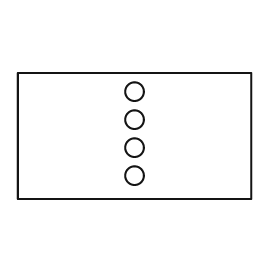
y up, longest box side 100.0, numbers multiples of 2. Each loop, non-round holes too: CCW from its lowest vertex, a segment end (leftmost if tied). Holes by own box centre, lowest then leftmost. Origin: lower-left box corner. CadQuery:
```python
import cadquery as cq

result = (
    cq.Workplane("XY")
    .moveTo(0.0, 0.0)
    .lineTo(100.0, 0.0)
    .lineTo(100.0, 54.0)
    .lineTo(0.0, 54.0)
    .close()
    .moveTo(50.0, 10.0)
    .circle(4.0)
    .moveTo(50.0, 22.0)
    .circle(4.0)
    .moveTo(50.0, 34.0)
    .circle(4.0)
    .moveTo(50.0, 46.0)
    .circle(4.0)
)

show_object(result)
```